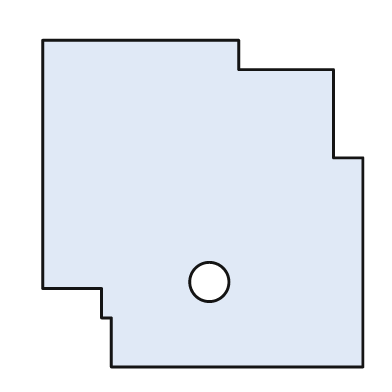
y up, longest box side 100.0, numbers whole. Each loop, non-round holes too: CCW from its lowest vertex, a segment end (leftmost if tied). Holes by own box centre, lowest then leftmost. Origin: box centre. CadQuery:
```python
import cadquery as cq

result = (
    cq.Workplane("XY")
    .moveTo(-28.0, -50.0)
    .lineTo(49.0, -50.0)
    .lineTo(49.0, 14.0)
    .lineTo(40.0, 14.0)
    .lineTo(40.0, 41.0)
    .lineTo(11.0, 41.0)
    .lineTo(11.0, 50.0)
    .lineTo(-49.0, 50.0)
    .lineTo(-49.0, -26.0)
    .lineTo(-31.0, -26.0)
    .lineTo(-31.0, -35.0)
    .lineTo(-28.0, -35.0)
    .close()
    .moveTo(2.0, -24.0)
    .circle(6.0)
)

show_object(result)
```